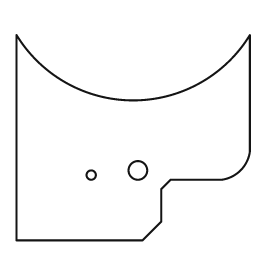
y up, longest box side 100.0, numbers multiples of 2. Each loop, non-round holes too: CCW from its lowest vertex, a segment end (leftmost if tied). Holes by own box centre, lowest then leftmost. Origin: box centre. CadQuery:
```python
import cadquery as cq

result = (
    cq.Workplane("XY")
    .moveTo(-50.0, -44.0)
    .lineTo(4.0, -44.0)
    .lineTo(12.0, -36.0)
    .lineTo(12.0, -22.0)
    .lineTo(16.0, -18.0)
    .lineTo(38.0, -18.0)
    .threePointArc((46.0, -14.0), (50.0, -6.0))
    .lineTo(50.0, 44.0)
    .threePointArc((0.0, 16.0), (-50.0, 44.0))
    .close()
    .moveTo(-18.0, -16.0)
    .circle(2.0)
    .moveTo(2.0, -14.0)
    .circle(4.0)
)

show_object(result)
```